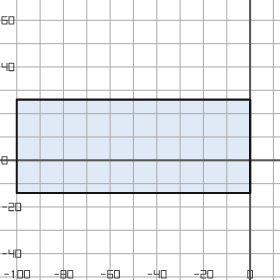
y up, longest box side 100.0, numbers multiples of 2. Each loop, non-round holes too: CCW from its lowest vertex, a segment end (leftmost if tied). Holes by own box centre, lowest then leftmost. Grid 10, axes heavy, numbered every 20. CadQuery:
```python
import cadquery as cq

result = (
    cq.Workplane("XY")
    .moveTo(-100.0, -14.0)
    .lineTo(0.0, -14.0)
    .lineTo(0.0, 26.0)
    .lineTo(-100.0, 26.0)
    .close()
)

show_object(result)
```